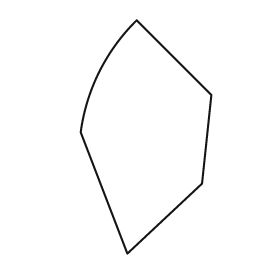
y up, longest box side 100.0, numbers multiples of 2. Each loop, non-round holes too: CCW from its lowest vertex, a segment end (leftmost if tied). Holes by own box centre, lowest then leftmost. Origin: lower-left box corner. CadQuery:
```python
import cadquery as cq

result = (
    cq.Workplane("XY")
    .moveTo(20.0, 0.0)
    .lineTo(52.0, 30.0)
    .lineTo(56.0, 68.0)
    .lineTo(24.0, 100.0)
    .threePointArc((8.0, 78.0), (0.0, 52.0))
    .close()
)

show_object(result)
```